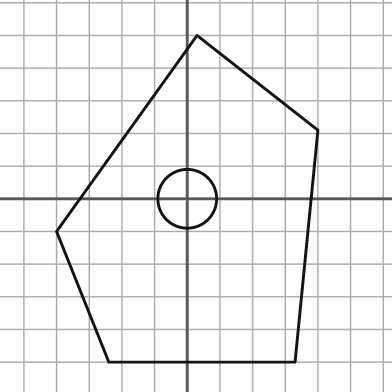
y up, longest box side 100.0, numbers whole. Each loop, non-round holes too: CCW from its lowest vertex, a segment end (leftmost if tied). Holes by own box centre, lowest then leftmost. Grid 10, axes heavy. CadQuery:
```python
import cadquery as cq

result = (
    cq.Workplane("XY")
    .moveTo(-24.0, -50.0)
    .lineTo(33.0, -50.0)
    .lineTo(40.0, 21.0)
    .lineTo(3.0, 50.0)
    .lineTo(-40.0, -10.0)
    .close()
    .moveTo(0.0, 0.0)
    .circle(9.0)
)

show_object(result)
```